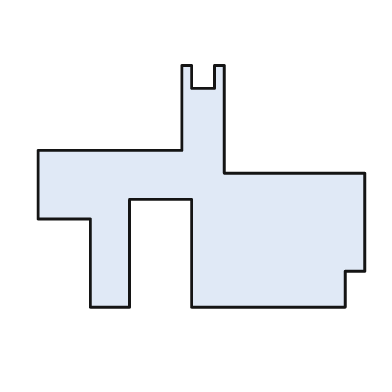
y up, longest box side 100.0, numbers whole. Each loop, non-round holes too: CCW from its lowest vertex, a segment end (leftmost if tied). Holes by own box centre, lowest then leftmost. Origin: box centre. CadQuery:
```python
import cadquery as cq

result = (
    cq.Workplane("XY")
    .moveTo(-34.0, -37.0)
    .lineTo(-22.0, -37.0)
    .lineTo(-22.0, -4.0)
    .lineTo(-3.0, -4.0)
    .lineTo(-3.0, -37.0)
    .lineTo(44.0, -37.0)
    .lineTo(44.0, -26.0)
    .lineTo(50.0, -26.0)
    .lineTo(50.0, 4.0)
    .lineTo(7.0, 4.0)
    .lineTo(7.0, 37.0)
    .lineTo(4.0, 37.0)
    .lineTo(4.0, 30.0)
    .lineTo(-3.0, 30.0)
    .lineTo(-3.0, 37.0)
    .lineTo(-6.0, 37.0)
    .lineTo(-6.0, 11.0)
    .lineTo(-50.0, 11.0)
    .lineTo(-50.0, -10.0)
    .lineTo(-34.0, -10.0)
    .close()
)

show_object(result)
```